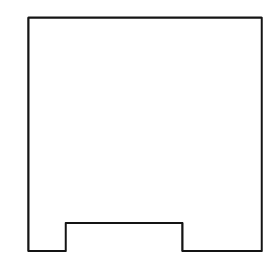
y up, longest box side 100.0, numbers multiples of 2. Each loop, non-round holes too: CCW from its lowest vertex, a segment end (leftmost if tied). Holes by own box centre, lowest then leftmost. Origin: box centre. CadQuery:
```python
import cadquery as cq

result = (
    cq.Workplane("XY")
    .moveTo(-50.0, -50.0)
    .lineTo(-34.0, -50.0)
    .lineTo(-34.0, -38.0)
    .lineTo(16.0, -38.0)
    .lineTo(16.0, -50.0)
    .lineTo(50.0, -50.0)
    .lineTo(50.0, 50.0)
    .lineTo(-50.0, 50.0)
    .close()
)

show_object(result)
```